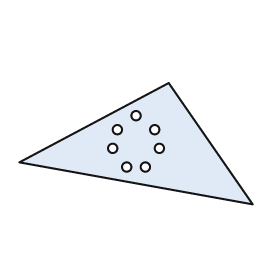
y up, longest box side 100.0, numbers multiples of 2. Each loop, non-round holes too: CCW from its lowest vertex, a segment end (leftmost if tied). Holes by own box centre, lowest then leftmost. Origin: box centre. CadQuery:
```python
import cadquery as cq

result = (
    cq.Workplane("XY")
    .moveTo(50.0, -26.0)
    .lineTo(14.0, 26.0)
    .lineTo(-50.0, -8.0)
    .close()
    .moveTo(-4.0, -10.0)
    .circle(2.0)
    .moveTo(4.0, -10.0)
    .circle(2.0)
    .moveTo(-10.0, -2.0)
    .circle(2.0)
    .moveTo(10.0, -2.0)
    .circle(2.0)
    .moveTo(-8.0, 6.0)
    .circle(2.0)
    .moveTo(8.0, 6.0)
    .circle(2.0)
    .moveTo(0.0, 12.0)
    .circle(2.0)
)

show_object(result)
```